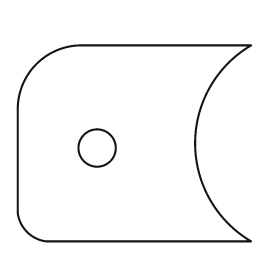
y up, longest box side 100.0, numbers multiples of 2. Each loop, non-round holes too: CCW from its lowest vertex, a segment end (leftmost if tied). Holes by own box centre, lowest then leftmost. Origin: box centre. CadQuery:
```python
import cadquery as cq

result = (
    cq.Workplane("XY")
    .moveTo(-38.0, -42.0)
    .lineTo(50.0, -42.0)
    .threePointArc((26.0, 0.0), (50.0, 42.0))
    .lineTo(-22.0, 42.0)
    .threePointArc((-42.0, 34.0), (-50.0, 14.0))
    .lineTo(-50.0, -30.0)
    .threePointArc((-46.0, -38.0), (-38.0, -42.0))
    .close()
    .moveTo(-16.0, -2.0)
    .circle(8.0)
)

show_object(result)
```